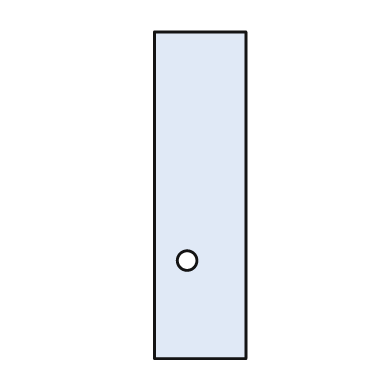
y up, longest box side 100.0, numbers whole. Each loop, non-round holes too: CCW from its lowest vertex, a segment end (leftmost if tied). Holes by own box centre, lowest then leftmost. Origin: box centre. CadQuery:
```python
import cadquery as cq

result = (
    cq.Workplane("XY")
    .moveTo(-14.0, -50.0)
    .lineTo(14.0, -50.0)
    .lineTo(14.0, 50.0)
    .lineTo(-14.0, 50.0)
    .close()
    .moveTo(-4.0, -20.0)
    .circle(3.0)
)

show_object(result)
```